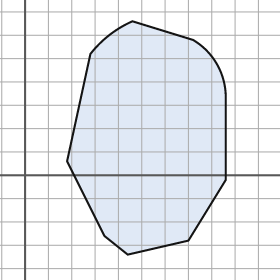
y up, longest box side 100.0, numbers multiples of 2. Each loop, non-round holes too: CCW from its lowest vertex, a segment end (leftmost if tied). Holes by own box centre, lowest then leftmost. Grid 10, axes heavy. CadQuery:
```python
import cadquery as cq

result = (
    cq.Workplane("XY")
    .moveTo(44.0, -34.0)
    .lineTo(70.0, -28.0)
    .lineTo(86.0, -2.0)
    .lineTo(86.0, 34.0)
    .threePointArc((82.0, 48.0), (72.0, 58.0))
    .lineTo(46.0, 66.0)
    .threePointArc((36.0, 60.0), (28.0, 52.0))
    .lineTo(18.0, 6.0)
    .lineTo(34.0, -26.0)
    .close()
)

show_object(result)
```